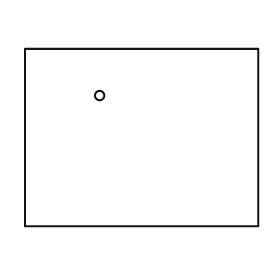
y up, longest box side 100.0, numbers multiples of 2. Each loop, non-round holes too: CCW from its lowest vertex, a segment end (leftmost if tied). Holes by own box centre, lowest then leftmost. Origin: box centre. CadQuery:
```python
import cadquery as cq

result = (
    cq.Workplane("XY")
    .moveTo(-50.0, -38.0)
    .lineTo(50.0, -38.0)
    .lineTo(50.0, 38.0)
    .lineTo(-50.0, 38.0)
    .close()
    .moveTo(-18.0, 18.0)
    .circle(2.0)
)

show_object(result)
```